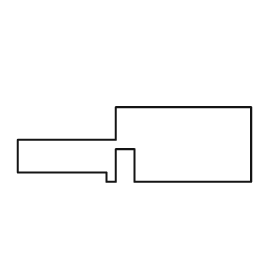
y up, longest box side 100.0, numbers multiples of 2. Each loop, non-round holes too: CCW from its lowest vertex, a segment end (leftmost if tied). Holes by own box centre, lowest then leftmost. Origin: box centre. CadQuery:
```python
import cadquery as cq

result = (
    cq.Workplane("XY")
    .moveTo(-12.0, -16.0)
    .lineTo(-8.0, -16.0)
    .lineTo(-8.0, -2.0)
    .lineTo(0.0, -2.0)
    .lineTo(0.0, -16.0)
    .lineTo(50.0, -16.0)
    .lineTo(50.0, 16.0)
    .lineTo(-8.0, 16.0)
    .lineTo(-8.0, 2.0)
    .lineTo(-50.0, 2.0)
    .lineTo(-50.0, -12.0)
    .lineTo(-12.0, -12.0)
    .close()
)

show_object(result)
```